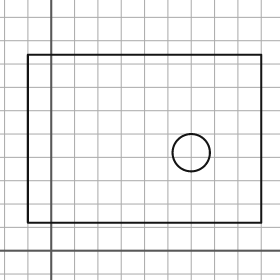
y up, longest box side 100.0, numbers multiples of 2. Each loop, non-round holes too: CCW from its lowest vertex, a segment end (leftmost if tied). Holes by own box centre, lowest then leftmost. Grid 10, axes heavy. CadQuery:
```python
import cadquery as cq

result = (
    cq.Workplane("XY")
    .moveTo(-10.0, 12.0)
    .lineTo(90.0, 12.0)
    .lineTo(90.0, 84.0)
    .lineTo(-10.0, 84.0)
    .close()
    .moveTo(60.0, 42.0)
    .circle(8.0)
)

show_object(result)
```